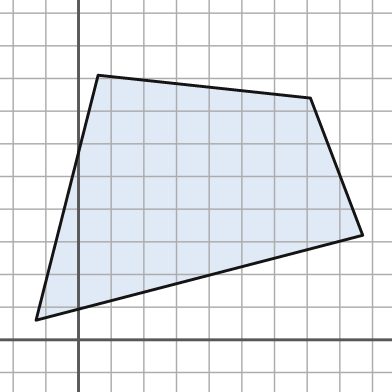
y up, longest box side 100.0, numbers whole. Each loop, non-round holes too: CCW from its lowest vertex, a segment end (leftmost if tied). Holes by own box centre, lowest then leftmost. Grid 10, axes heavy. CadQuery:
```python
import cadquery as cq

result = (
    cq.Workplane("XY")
    .moveTo(-13.0, 6.0)
    .lineTo(87.0, 32.0)
    .lineTo(71.0, 74.0)
    .lineTo(6.0, 81.0)
    .close()
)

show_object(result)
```